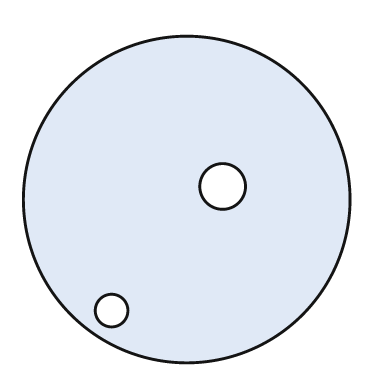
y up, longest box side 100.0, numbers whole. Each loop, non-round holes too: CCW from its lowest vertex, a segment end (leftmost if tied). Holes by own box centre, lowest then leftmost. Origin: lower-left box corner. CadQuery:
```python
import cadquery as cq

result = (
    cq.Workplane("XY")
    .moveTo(50.0, 50.0)
    .circle(50.0)
    .moveTo(27.0, 16.0)
    .circle(5.0)
    .moveTo(61.0, 54.0)
    .circle(7.0)
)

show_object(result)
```